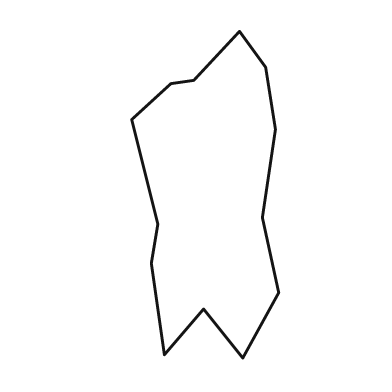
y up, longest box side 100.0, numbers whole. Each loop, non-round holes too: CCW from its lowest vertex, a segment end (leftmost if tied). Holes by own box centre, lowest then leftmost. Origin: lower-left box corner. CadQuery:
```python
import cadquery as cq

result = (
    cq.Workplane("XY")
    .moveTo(34.0, 0.0)
    .lineTo(45.0, 20.0)
    .lineTo(40.0, 43.0)
    .lineTo(44.0, 70.0)
    .lineTo(41.0, 89.0)
    .lineTo(33.0, 100.0)
    .lineTo(19.0, 85.0)
    .lineTo(12.0, 84.0)
    .lineTo(0.0, 73.0)
    .lineTo(8.0, 41.0)
    .lineTo(6.0, 29.0)
    .lineTo(10.0, 1.0)
    .lineTo(22.0, 15.0)
    .close()
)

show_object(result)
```